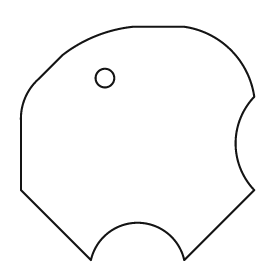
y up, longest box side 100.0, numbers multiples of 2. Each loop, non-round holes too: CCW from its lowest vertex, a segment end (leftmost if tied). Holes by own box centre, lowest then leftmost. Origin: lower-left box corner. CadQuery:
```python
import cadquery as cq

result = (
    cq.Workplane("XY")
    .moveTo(30.0, 0.0)
    .threePointArc((50.0, 16.0), (70.0, 0.0))
    .lineTo(100.0, 30.0)
    .threePointArc((92.0, 50.0), (100.0, 70.0))
    .threePointArc((90.0, 90.0), (70.0, 100.0))
    .lineTo(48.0, 100.0)
    .threePointArc((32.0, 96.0), (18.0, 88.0))
    .lineTo(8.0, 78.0)
    .threePointArc((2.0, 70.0), (0.0, 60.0))
    .lineTo(0.0, 30.0)
    .close()
    .moveTo(36.0, 78.0)
    .circle(4.0)
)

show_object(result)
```